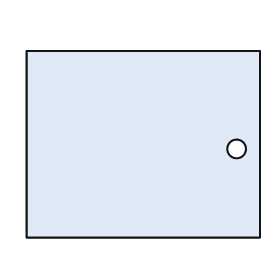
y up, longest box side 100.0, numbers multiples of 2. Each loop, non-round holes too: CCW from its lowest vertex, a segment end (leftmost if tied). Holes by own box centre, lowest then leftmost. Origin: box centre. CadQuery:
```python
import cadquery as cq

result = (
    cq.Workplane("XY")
    .moveTo(-50.0, -40.0)
    .lineTo(50.0, -40.0)
    .lineTo(50.0, 40.0)
    .lineTo(-50.0, 40.0)
    .close()
    .moveTo(40.0, -2.0)
    .circle(4.0)
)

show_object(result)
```